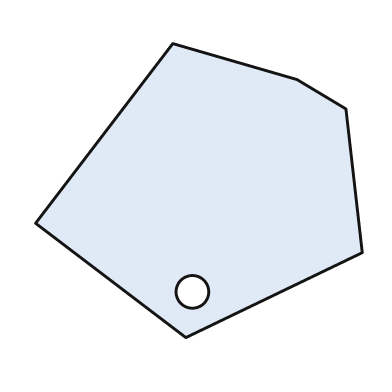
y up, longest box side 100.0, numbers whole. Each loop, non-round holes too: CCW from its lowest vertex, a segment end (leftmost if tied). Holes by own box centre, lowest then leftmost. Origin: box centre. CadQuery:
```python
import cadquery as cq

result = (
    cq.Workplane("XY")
    .moveTo(-4.0, -45.0)
    .lineTo(50.0, -19.0)
    .lineTo(45.0, 25.0)
    .lineTo(30.0, 34.0)
    .lineTo(-8.0, 45.0)
    .lineTo(-50.0, -10.0)
    .close()
    .moveTo(-2.0, -31.0)
    .circle(5.0)
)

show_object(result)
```